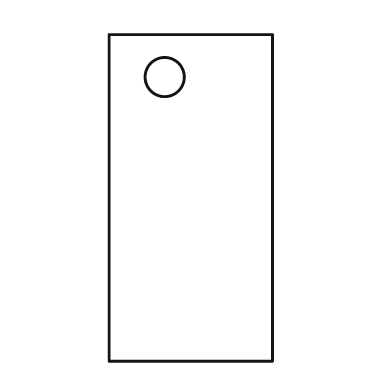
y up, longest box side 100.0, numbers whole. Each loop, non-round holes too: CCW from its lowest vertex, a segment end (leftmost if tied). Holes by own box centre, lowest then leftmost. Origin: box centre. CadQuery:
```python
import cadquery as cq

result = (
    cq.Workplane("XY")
    .moveTo(-25.0, -50.0)
    .lineTo(25.0, -50.0)
    .lineTo(25.0, 50.0)
    .lineTo(-25.0, 50.0)
    .close()
    .moveTo(-8.0, 37.0)
    .circle(6.0)
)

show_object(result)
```